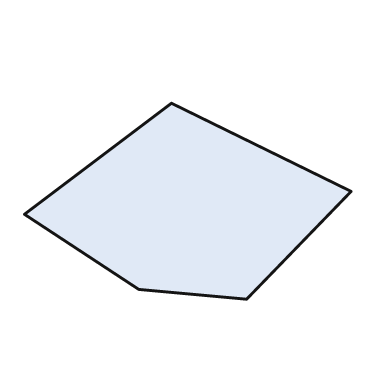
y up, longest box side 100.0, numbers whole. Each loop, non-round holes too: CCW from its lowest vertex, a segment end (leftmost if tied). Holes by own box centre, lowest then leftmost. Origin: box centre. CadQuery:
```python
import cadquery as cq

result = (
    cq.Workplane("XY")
    .moveTo(18.0, -30.0)
    .lineTo(50.0, 3.0)
    .lineTo(-5.0, 30.0)
    .lineTo(-50.0, -4.0)
    .lineTo(-15.0, -27.0)
    .close()
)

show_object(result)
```